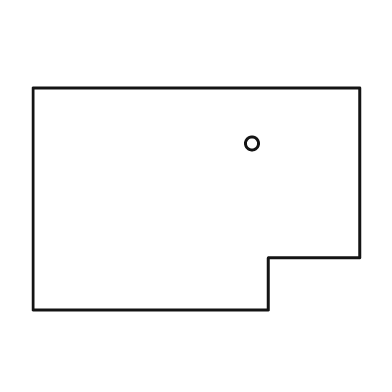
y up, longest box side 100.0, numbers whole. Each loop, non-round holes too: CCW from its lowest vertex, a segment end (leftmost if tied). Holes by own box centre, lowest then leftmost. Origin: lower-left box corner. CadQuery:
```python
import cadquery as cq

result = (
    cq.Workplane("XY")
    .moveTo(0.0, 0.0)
    .lineTo(72.0, 0.0)
    .lineTo(72.0, 16.0)
    .lineTo(100.0, 16.0)
    .lineTo(100.0, 68.0)
    .lineTo(0.0, 68.0)
    .close()
    .moveTo(67.0, 51.0)
    .circle(2.0)
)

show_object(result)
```